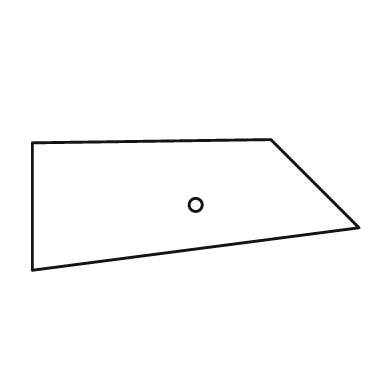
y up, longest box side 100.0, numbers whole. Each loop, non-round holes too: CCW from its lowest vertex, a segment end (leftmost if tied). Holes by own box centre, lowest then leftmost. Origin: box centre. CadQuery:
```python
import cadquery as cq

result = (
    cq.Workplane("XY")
    .moveTo(-50.0, -20.0)
    .lineTo(50.0, -7.0)
    .lineTo(23.0, 20.0)
    .lineTo(-50.0, 19.0)
    .close()
    .moveTo(0.0, 0.0)
    .circle(2.0)
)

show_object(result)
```